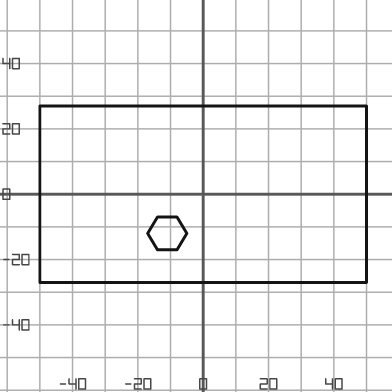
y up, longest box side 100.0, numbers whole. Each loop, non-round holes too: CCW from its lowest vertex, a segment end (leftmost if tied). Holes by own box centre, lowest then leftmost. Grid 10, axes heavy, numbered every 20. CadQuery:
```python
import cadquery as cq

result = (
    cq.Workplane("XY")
    .moveTo(-50.0, -27.0)
    .lineTo(50.0, -27.0)
    .lineTo(50.0, 27.0)
    .lineTo(-50.0, 27.0)
    .close()
    .moveTo(-14.0, -17.0)
    .lineTo(-8.0, -17.0)
    .lineTo(-5.0, -12.0)
    .lineTo(-8.0, -7.0)
    .lineTo(-14.0, -7.0)
    .lineTo(-17.0, -12.0)
    .close()
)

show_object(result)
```